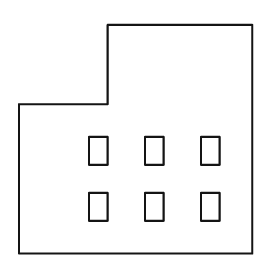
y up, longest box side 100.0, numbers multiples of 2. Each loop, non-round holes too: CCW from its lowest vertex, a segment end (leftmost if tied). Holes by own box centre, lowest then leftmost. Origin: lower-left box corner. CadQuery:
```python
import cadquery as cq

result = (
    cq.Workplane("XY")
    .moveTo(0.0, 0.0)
    .lineTo(100.0, 0.0)
    .lineTo(100.0, 98.0)
    .lineTo(38.0, 98.0)
    .lineTo(38.0, 64.0)
    .lineTo(0.0, 64.0)
    .close()
    .moveTo(30.0, 14.0)
    .lineTo(38.0, 14.0)
    .lineTo(38.0, 26.0)
    .lineTo(30.0, 26.0)
    .close()
    .moveTo(54.0, 14.0)
    .lineTo(62.0, 14.0)
    .lineTo(62.0, 26.0)
    .lineTo(54.0, 26.0)
    .close()
    .moveTo(78.0, 14.0)
    .lineTo(86.0, 14.0)
    .lineTo(86.0, 26.0)
    .lineTo(78.0, 26.0)
    .close()
    .moveTo(30.0, 38.0)
    .lineTo(38.0, 38.0)
    .lineTo(38.0, 50.0)
    .lineTo(30.0, 50.0)
    .close()
    .moveTo(54.0, 38.0)
    .lineTo(62.0, 38.0)
    .lineTo(62.0, 50.0)
    .lineTo(54.0, 50.0)
    .close()
    .moveTo(78.0, 38.0)
    .lineTo(86.0, 38.0)
    .lineTo(86.0, 50.0)
    .lineTo(78.0, 50.0)
    .close()
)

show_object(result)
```